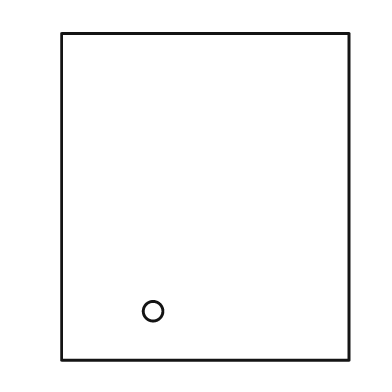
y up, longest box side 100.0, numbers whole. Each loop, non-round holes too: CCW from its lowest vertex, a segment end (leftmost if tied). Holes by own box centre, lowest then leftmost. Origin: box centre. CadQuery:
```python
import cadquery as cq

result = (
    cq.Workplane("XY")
    .moveTo(-44.0, -50.0)
    .lineTo(44.0, -50.0)
    .lineTo(44.0, 50.0)
    .lineTo(-44.0, 50.0)
    .close()
    .moveTo(-16.0, -35.0)
    .circle(3.0)
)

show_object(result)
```